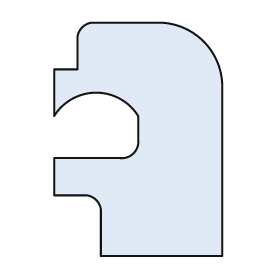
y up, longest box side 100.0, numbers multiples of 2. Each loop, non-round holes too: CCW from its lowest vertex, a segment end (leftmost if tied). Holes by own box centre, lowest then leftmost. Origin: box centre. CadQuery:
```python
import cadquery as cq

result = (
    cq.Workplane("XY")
    .moveTo(-16.0, -50.0)
    .lineTo(36.0, -50.0)
    .lineTo(36.0, 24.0)
    .threePointArc((28.0, 42.0), (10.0, 50.0))
    .lineTo(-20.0, 50.0)
    .threePointArc((-24.0, 48.0), (-26.0, 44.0))
    .lineTo(-26.0, 30.0)
    .lineTo(-36.0, 30.0)
    .lineTo(-36.0, 10.0)
    .threePointArc((-18.0, 20.0), (0.0, 10.0))
    .lineTo(0.0, 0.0)
    .threePointArc((-2.0, -6.0), (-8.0, -8.0))
    .lineTo(-36.0, -8.0)
    .lineTo(-36.0, -24.0)
    .lineTo(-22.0, -24.0)
    .threePointArc((-18.0, -26.0), (-16.0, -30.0))
    .close()
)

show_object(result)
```